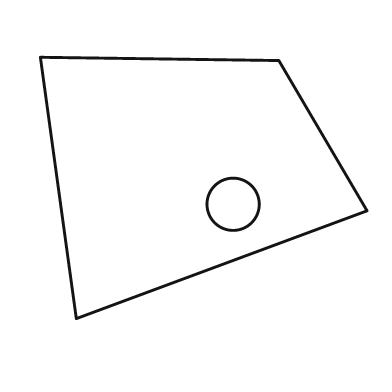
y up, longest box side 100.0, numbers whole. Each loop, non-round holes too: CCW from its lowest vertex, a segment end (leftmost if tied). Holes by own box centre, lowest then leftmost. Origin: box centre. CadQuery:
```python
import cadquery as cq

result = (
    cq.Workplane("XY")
    .moveTo(-39.0, -40.0)
    .lineTo(50.0, -7.0)
    .lineTo(23.0, 39.0)
    .lineTo(-50.0, 40.0)
    .close()
    .moveTo(9.0, -5.0)
    .circle(8.0)
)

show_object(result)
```